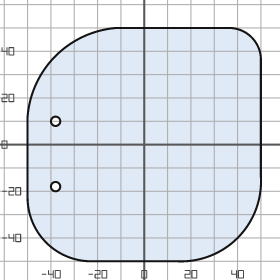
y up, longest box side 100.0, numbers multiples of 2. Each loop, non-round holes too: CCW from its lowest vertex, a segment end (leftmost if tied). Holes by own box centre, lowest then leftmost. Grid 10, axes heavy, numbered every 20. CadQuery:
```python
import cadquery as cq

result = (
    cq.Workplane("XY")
    .moveTo(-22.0, -50.0)
    .lineTo(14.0, -50.0)
    .threePointArc((40.0, -40.0), (50.0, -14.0))
    .lineTo(50.0, 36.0)
    .threePointArc((46.0, 46.0), (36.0, 50.0))
    .lineTo(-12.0, 50.0)
    .threePointArc((-38.0, 38.0), (-50.0, 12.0))
    .lineTo(-50.0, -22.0)
    .threePointArc((-42.0, -42.0), (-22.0, -50.0))
    .close()
    .moveTo(-38.0, -18.0)
    .circle(2.0)
    .moveTo(-38.0, 10.0)
    .circle(2.0)
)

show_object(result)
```